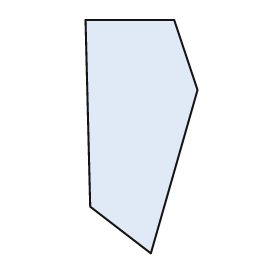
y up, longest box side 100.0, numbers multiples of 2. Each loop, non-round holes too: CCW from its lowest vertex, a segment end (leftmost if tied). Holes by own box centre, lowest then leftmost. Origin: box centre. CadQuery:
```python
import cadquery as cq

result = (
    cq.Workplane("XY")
    .moveTo(4.0, -50.0)
    .lineTo(24.0, 20.0)
    .lineTo(14.0, 50.0)
    .lineTo(-24.0, 50.0)
    .lineTo(-22.0, -30.0)
    .close()
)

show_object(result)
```